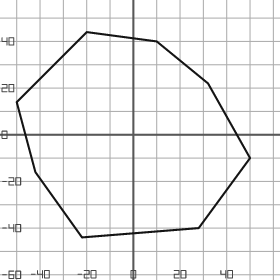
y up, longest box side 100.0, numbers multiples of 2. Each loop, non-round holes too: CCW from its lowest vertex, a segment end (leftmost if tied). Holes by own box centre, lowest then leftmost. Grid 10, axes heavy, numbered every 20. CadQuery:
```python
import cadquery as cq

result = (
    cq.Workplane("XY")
    .moveTo(-22.0, -44.0)
    .lineTo(28.0, -40.0)
    .lineTo(50.0, -10.0)
    .lineTo(32.0, 22.0)
    .lineTo(10.0, 40.0)
    .lineTo(-20.0, 44.0)
    .lineTo(-50.0, 14.0)
    .lineTo(-42.0, -16.0)
    .close()
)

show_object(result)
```